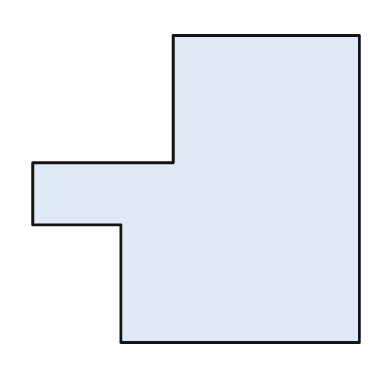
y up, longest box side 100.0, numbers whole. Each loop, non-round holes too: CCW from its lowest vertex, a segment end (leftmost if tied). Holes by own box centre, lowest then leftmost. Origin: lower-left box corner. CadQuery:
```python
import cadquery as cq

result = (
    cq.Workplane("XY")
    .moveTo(27.0, 0.0)
    .lineTo(100.0, 0.0)
    .lineTo(100.0, 94.0)
    .lineTo(43.0, 94.0)
    .lineTo(43.0, 55.0)
    .lineTo(0.0, 55.0)
    .lineTo(0.0, 36.0)
    .lineTo(27.0, 36.0)
    .close()
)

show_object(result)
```